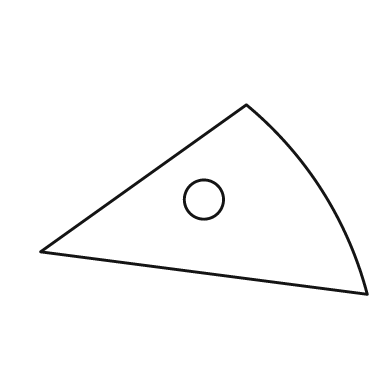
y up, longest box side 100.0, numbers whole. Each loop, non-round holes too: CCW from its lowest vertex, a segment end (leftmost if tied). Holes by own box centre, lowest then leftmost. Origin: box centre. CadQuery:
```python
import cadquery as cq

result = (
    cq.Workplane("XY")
    .moveTo(50.0, -29.0)
    .threePointArc((36.0, 3.0), (13.0, 29.0))
    .lineTo(-50.0, -16.0)
    .close()
    .moveTo(0.0, 0.0)
    .circle(6.0)
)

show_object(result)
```